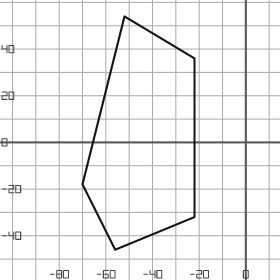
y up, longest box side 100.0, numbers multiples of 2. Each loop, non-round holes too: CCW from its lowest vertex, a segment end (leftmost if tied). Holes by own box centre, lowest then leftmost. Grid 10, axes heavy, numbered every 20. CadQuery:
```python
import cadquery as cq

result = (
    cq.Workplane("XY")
    .moveTo(-56.0, -46.0)
    .lineTo(-22.0, -32.0)
    .lineTo(-22.0, 36.0)
    .lineTo(-52.0, 54.0)
    .lineTo(-70.0, -18.0)
    .close()
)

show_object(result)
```